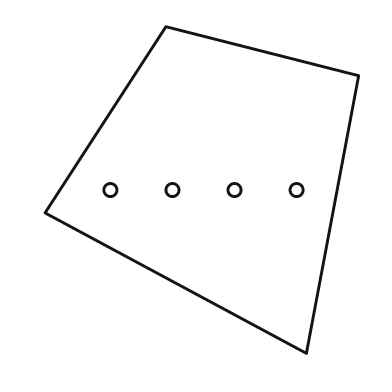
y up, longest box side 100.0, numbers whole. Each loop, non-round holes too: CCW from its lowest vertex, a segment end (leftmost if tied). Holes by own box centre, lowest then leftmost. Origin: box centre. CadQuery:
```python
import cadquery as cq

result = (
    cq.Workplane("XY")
    .moveTo(32.0, -50.0)
    .lineTo(48.0, 35.0)
    .lineTo(-11.0, 50.0)
    .lineTo(-48.0, -7.0)
    .close()
    .moveTo(-28.0, 0.0)
    .circle(2.0)
    .moveTo(-9.0, 0.0)
    .circle(2.0)
    .moveTo(10.0, 0.0)
    .circle(2.0)
    .moveTo(29.0, 0.0)
    .circle(2.0)
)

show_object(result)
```